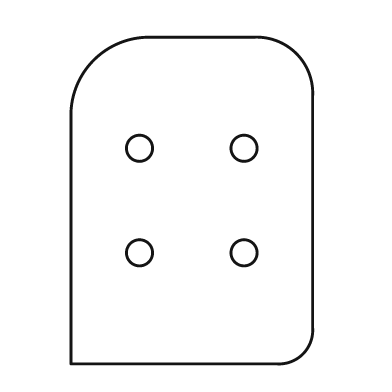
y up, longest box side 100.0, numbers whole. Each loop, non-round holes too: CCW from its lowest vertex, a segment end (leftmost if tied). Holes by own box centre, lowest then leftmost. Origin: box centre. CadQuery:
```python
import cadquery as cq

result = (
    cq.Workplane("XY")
    .moveTo(-37.0, -50.0)
    .lineTo(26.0, -50.0)
    .threePointArc((34.0, -47.0), (37.0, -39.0))
    .lineTo(37.0, 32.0)
    .threePointArc((32.0, 45.0), (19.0, 50.0))
    .lineTo(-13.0, 50.0)
    .threePointArc((-30.0, 43.0), (-37.0, 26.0))
    .close()
    .moveTo(-16.0, -16.0)
    .circle(4.0)
    .moveTo(16.0, -16.0)
    .circle(4.0)
    .moveTo(-16.0, 16.0)
    .circle(4.0)
    .moveTo(16.0, 16.0)
    .circle(4.0)
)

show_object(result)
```